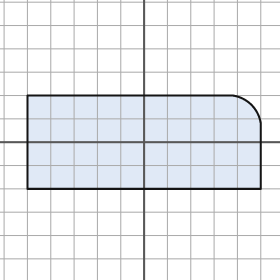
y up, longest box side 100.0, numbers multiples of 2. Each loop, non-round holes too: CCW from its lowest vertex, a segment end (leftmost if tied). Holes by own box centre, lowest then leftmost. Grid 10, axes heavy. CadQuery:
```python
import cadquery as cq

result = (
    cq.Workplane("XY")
    .moveTo(-50.0, -20.0)
    .lineTo(50.0, -20.0)
    .lineTo(50.0, 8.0)
    .threePointArc((46.0, 16.0), (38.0, 20.0))
    .lineTo(-50.0, 20.0)
    .close()
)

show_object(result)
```